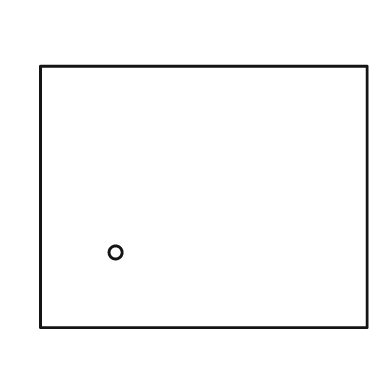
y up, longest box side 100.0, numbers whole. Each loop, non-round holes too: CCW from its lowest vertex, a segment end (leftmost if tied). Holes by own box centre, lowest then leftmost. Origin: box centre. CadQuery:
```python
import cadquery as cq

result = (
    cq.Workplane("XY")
    .moveTo(-50.0, -40.0)
    .lineTo(50.0, -40.0)
    .lineTo(50.0, 40.0)
    .lineTo(-50.0, 40.0)
    .close()
    .moveTo(-27.0, -17.0)
    .circle(2.0)
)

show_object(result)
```